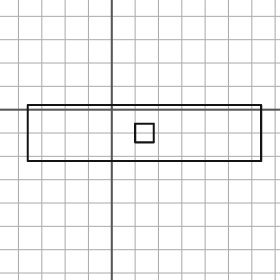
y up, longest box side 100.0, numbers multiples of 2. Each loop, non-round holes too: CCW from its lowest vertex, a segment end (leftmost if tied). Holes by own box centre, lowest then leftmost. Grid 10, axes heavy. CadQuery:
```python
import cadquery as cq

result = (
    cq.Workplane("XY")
    .moveTo(-36.0, -22.0)
    .lineTo(64.0, -22.0)
    .lineTo(64.0, 2.0)
    .lineTo(-36.0, 2.0)
    .close()
    .moveTo(10.0, -14.0)
    .lineTo(18.0, -14.0)
    .lineTo(18.0, -6.0)
    .lineTo(10.0, -6.0)
    .close()
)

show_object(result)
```